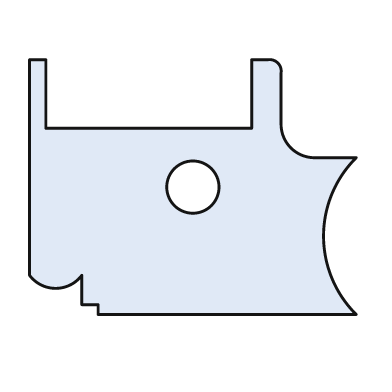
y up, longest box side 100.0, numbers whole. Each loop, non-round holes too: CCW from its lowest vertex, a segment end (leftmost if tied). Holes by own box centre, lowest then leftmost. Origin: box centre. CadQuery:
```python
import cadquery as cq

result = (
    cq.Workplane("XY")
    .moveTo(-29.0, -39.0)
    .lineTo(50.0, -39.0)
    .threePointArc((40.0, -15.0), (50.0, 9.0))
    .lineTo(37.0, 9.0)
    .threePointArc((30.0, 12.0), (27.0, 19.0))
    .lineTo(27.0, 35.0)
    .threePointArc((26.0, 38.0), (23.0, 39.0))
    .lineTo(18.0, 39.0)
    .lineTo(18.0, 18.0)
    .lineTo(-45.0, 18.0)
    .lineTo(-45.0, 39.0)
    .lineTo(-50.0, 39.0)
    .lineTo(-50.0, -27.0)
    .threePointArc((-42.0, -31.0), (-34.0, -27.0))
    .lineTo(-34.0, -36.0)
    .lineTo(-29.0, -36.0)
    .close()
    .moveTo(0.0, 0.0)
    .circle(8.0)
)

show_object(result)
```